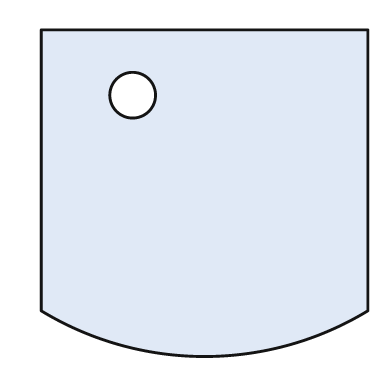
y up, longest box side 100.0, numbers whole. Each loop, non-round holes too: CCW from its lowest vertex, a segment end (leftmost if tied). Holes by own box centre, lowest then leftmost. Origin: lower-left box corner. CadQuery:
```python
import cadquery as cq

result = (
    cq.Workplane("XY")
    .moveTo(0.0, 14.0)
    .threePointArc((50.0, 0.0), (100.0, 14.0))
    .lineTo(100.0, 100.0)
    .lineTo(0.0, 100.0)
    .close()
    .moveTo(28.0, 80.0)
    .circle(7.0)
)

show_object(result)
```